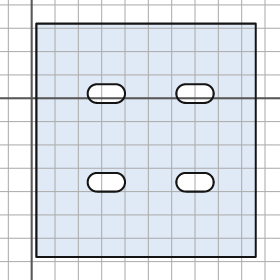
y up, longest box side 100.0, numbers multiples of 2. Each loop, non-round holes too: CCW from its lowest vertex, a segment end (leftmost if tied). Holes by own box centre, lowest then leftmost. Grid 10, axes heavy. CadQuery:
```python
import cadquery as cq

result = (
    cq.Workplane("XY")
    .moveTo(2.0, -68.0)
    .lineTo(96.0, -68.0)
    .lineTo(96.0, 32.0)
    .lineTo(2.0, 32.0)
    .close()
    .moveTo(28.0, -40.0)
    .lineTo(36.0, -40.0)
    .threePointArc((40.0, -36.0), (36.0, -32.0))
    .lineTo(28.0, -32.0)
    .threePointArc((24.0, -36.0), (28.0, -40.0))
    .close()
    .moveTo(66.0, -40.0)
    .lineTo(74.0, -40.0)
    .threePointArc((78.0, -36.0), (74.0, -32.0))
    .lineTo(66.0, -32.0)
    .threePointArc((62.0, -36.0), (66.0, -40.0))
    .close()
    .moveTo(28.0, -2.0)
    .lineTo(36.0, -2.0)
    .threePointArc((40.0, 2.0), (36.0, 6.0))
    .lineTo(28.0, 6.0)
    .threePointArc((24.0, 2.0), (28.0, -2.0))
    .close()
    .moveTo(66.0, -2.0)
    .lineTo(74.0, -2.0)
    .threePointArc((78.0, 2.0), (74.0, 6.0))
    .lineTo(66.0, 6.0)
    .threePointArc((62.0, 2.0), (66.0, -2.0))
    .close()
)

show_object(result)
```